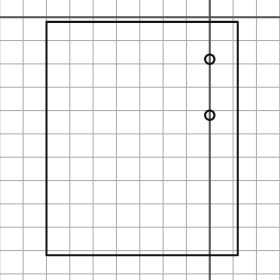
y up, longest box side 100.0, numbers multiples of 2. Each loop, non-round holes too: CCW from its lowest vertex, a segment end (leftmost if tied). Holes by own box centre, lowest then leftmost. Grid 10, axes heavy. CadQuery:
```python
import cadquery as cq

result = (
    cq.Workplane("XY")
    .moveTo(-70.0, -102.0)
    .lineTo(12.0, -102.0)
    .lineTo(12.0, -2.0)
    .lineTo(-70.0, -2.0)
    .close()
    .moveTo(0.0, -42.0)
    .circle(2.0)
    .moveTo(0.0, -18.0)
    .circle(2.0)
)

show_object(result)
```